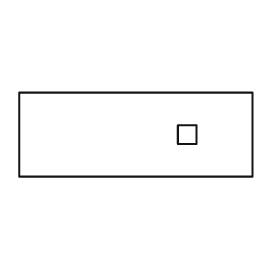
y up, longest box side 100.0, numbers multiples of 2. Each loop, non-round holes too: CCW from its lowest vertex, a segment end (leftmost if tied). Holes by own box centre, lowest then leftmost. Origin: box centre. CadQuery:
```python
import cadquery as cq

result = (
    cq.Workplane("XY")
    .moveTo(-50.0, -18.0)
    .lineTo(50.0, -18.0)
    .lineTo(50.0, 18.0)
    .lineTo(-50.0, 18.0)
    .close()
    .moveTo(18.0, -4.0)
    .lineTo(26.0, -4.0)
    .lineTo(26.0, 4.0)
    .lineTo(18.0, 4.0)
    .close()
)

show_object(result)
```